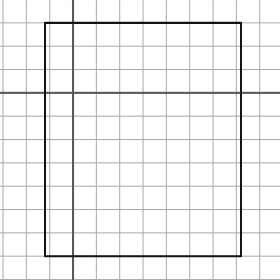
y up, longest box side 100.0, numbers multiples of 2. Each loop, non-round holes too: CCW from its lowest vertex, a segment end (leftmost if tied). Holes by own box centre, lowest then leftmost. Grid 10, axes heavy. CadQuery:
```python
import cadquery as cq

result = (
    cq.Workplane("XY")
    .moveTo(-12.0, -70.0)
    .lineTo(72.0, -70.0)
    .lineTo(72.0, 30.0)
    .lineTo(-12.0, 30.0)
    .close()
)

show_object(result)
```